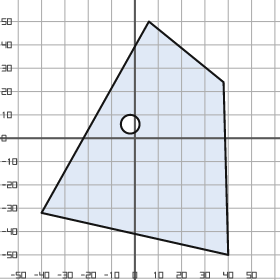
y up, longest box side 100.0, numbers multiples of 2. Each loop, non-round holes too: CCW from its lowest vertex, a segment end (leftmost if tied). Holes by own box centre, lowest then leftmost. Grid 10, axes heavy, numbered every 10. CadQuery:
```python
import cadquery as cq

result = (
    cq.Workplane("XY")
    .moveTo(40.0, -50.0)
    .lineTo(38.0, 24.0)
    .lineTo(6.0, 50.0)
    .lineTo(-40.0, -32.0)
    .close()
    .moveTo(-2.0, 6.0)
    .circle(4.0)
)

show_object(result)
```